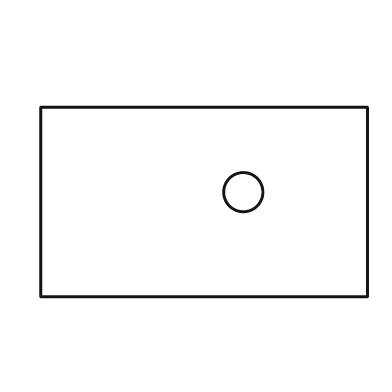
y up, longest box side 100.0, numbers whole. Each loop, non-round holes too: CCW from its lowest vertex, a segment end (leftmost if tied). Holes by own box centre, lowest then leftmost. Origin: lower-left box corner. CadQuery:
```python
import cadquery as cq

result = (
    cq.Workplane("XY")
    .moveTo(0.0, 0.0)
    .lineTo(100.0, 0.0)
    .lineTo(100.0, 58.0)
    .lineTo(0.0, 58.0)
    .close()
    .moveTo(62.0, 32.0)
    .circle(6.0)
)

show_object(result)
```